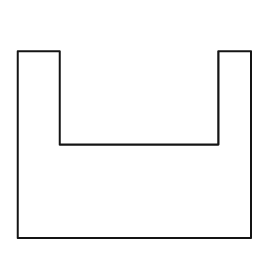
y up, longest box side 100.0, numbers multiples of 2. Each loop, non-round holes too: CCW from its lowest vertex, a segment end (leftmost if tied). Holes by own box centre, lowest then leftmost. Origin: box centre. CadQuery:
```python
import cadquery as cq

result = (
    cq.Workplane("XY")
    .moveTo(-50.0, -40.0)
    .lineTo(50.0, -40.0)
    .lineTo(50.0, 40.0)
    .lineTo(36.0, 40.0)
    .lineTo(36.0, 0.0)
    .lineTo(-32.0, 0.0)
    .lineTo(-32.0, 40.0)
    .lineTo(-50.0, 40.0)
    .close()
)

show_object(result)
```